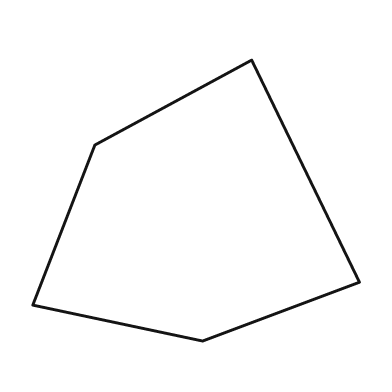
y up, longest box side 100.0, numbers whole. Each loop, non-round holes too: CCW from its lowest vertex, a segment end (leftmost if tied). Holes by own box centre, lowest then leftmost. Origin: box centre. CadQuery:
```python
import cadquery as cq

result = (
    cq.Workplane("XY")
    .moveTo(2.0, -43.0)
    .lineTo(50.0, -25.0)
    .lineTo(17.0, 43.0)
    .lineTo(-31.0, 17.0)
    .lineTo(-50.0, -32.0)
    .close()
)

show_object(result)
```